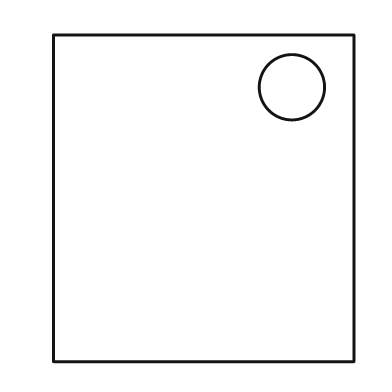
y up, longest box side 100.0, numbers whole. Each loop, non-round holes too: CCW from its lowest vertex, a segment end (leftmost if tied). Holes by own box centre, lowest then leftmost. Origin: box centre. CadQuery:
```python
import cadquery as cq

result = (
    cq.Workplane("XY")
    .moveTo(-46.0, -50.0)
    .lineTo(46.0, -50.0)
    .lineTo(46.0, 50.0)
    .lineTo(-46.0, 50.0)
    .close()
    .moveTo(27.0, 34.0)
    .circle(10.0)
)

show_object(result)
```